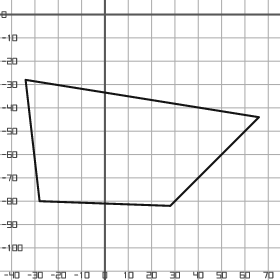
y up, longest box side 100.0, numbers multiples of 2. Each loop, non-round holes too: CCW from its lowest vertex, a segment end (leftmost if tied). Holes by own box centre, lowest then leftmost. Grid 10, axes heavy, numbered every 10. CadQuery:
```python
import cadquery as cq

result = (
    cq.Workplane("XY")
    .moveTo(28.0, -82.0)
    .lineTo(66.0, -44.0)
    .lineTo(-34.0, -28.0)
    .lineTo(-28.0, -80.0)
    .close()
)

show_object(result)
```